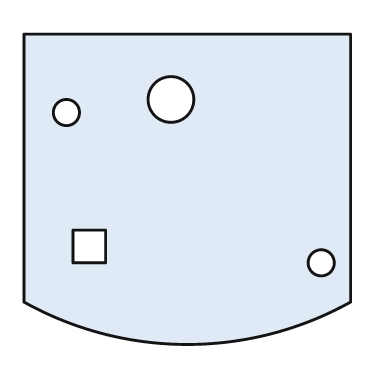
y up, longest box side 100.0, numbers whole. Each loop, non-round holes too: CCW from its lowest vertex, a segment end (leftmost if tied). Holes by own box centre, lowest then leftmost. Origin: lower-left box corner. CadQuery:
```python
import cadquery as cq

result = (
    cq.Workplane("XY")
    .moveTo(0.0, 13.0)
    .threePointArc((50.0, 0.0), (100.0, 13.0))
    .lineTo(100.0, 95.0)
    .lineTo(0.0, 95.0)
    .close()
    .moveTo(91.0, 25.0)
    .circle(4.0)
    .moveTo(15.0, 25.0)
    .lineTo(25.0, 25.0)
    .lineTo(25.0, 35.0)
    .lineTo(15.0, 35.0)
    .close()
    .moveTo(13.0, 71.0)
    .circle(4.0)
    .moveTo(45.0, 75.0)
    .circle(7.0)
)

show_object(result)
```